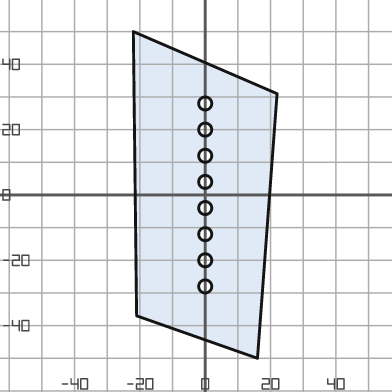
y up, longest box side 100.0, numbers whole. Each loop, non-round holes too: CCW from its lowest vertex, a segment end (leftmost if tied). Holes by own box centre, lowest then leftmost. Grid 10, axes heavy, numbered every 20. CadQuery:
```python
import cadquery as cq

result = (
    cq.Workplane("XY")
    .moveTo(16.0, -50.0)
    .lineTo(22.0, 31.0)
    .lineTo(-22.0, 50.0)
    .lineTo(-21.0, -37.0)
    .close()
    .moveTo(0.0, -28.0)
    .circle(2.0)
    .moveTo(0.0, -20.0)
    .circle(2.0)
    .moveTo(0.0, -12.0)
    .circle(2.0)
    .moveTo(0.0, -4.0)
    .circle(2.0)
    .moveTo(0.0, 4.0)
    .circle(2.0)
    .moveTo(0.0, 12.0)
    .circle(2.0)
    .moveTo(0.0, 20.0)
    .circle(2.0)
    .moveTo(0.0, 28.0)
    .circle(2.0)
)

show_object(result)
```